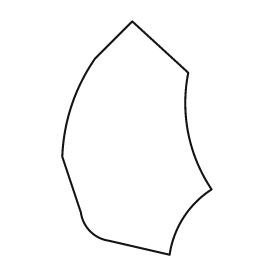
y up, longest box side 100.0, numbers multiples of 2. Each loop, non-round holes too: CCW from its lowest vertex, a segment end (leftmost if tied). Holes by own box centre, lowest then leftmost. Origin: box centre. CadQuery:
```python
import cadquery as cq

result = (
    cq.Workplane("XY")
    .moveTo(14.0, -50.0)
    .threePointArc((20.0, -34.0), (32.0, -22.0))
    .threePointArc((22.0, 2.0), (22.0, 28.0))
    .lineTo(-2.0, 50.0)
    .lineTo(-18.0, 34.0)
    .threePointArc((-28.0, 14.0), (-32.0, -8.0))
    .lineTo(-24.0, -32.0)
    .threePointArc((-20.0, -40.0), (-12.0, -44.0))
    .close()
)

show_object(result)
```